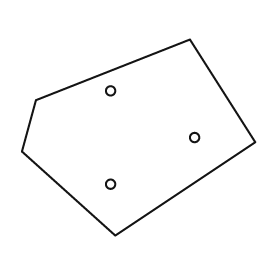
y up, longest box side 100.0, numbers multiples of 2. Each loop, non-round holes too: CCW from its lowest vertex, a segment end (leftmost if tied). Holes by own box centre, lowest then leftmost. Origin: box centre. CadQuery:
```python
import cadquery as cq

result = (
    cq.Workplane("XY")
    .moveTo(-10.0, -42.0)
    .lineTo(50.0, -2.0)
    .lineTo(22.0, 42.0)
    .lineTo(-44.0, 16.0)
    .lineTo(-50.0, -6.0)
    .close()
    .moveTo(-12.0, -20.0)
    .circle(2.0)
    .moveTo(24.0, 0.0)
    .circle(2.0)
    .moveTo(-12.0, 20.0)
    .circle(2.0)
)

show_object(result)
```